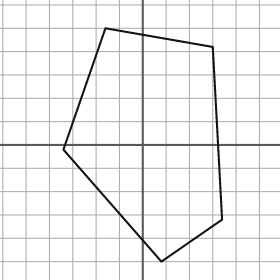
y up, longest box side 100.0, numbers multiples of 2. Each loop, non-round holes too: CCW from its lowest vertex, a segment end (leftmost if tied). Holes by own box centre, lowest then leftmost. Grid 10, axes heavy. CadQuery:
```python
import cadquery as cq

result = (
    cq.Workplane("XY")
    .moveTo(8.0, -50.0)
    .lineTo(34.0, -32.0)
    .lineTo(30.0, 42.0)
    .lineTo(-16.0, 50.0)
    .lineTo(-34.0, -2.0)
    .close()
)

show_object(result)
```